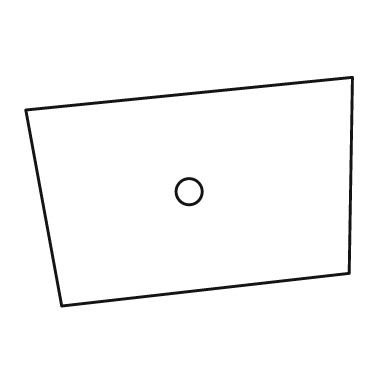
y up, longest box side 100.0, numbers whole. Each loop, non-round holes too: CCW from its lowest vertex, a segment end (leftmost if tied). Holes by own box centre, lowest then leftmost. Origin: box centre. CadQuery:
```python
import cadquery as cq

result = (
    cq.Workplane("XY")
    .moveTo(-39.0, -35.0)
    .lineTo(49.0, -25.0)
    .lineTo(50.0, 35.0)
    .lineTo(-50.0, 25.0)
    .close()
    .moveTo(0.0, 0.0)
    .circle(4.0)
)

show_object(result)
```